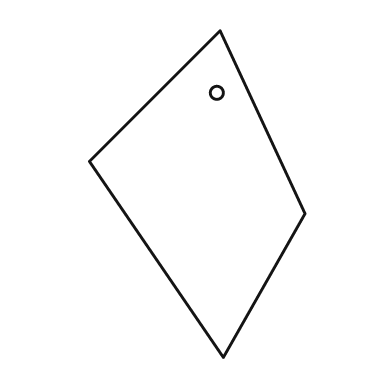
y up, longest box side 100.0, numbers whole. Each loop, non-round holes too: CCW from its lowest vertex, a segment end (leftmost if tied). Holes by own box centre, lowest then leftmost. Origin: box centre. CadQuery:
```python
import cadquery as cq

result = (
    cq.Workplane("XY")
    .moveTo(8.0, -50.0)
    .lineTo(33.0, -6.0)
    .lineTo(7.0, 50.0)
    .lineTo(-33.0, 10.0)
    .close()
    .moveTo(6.0, 31.0)
    .circle(2.0)
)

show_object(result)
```